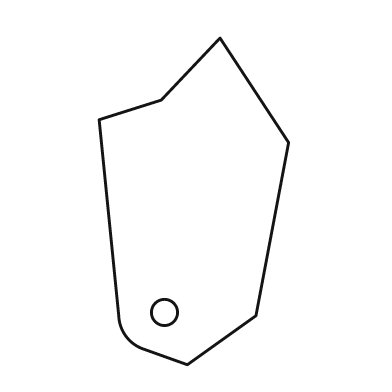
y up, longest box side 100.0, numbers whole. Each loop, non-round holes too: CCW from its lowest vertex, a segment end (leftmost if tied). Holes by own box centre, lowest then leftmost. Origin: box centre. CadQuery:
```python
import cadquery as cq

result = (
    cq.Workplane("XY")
    .moveTo(-2.0, -50.0)
    .lineTo(19.0, -35.0)
    .lineTo(29.0, 18.0)
    .lineTo(8.0, 50.0)
    .lineTo(-10.0, 31.0)
    .lineTo(-29.0, 25.0)
    .lineTo(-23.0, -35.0)
    .threePointArc((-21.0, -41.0), (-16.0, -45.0))
    .close()
    .moveTo(-9.0, -34.0)
    .circle(4.0)
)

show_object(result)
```